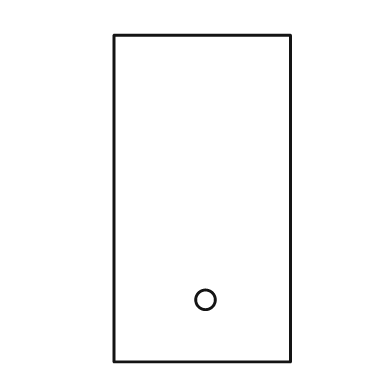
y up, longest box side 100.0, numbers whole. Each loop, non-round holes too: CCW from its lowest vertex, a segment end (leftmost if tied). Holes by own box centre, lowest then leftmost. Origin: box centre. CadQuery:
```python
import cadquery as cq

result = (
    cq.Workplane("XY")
    .moveTo(-27.0, -50.0)
    .lineTo(27.0, -50.0)
    .lineTo(27.0, 50.0)
    .lineTo(-27.0, 50.0)
    .close()
    .moveTo(1.0, -31.0)
    .circle(3.0)
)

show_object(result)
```